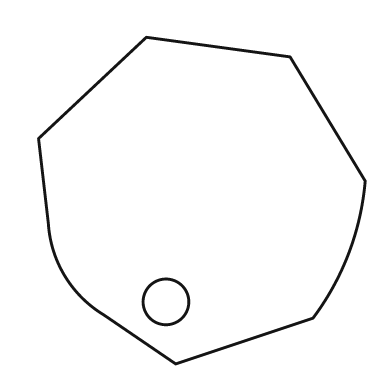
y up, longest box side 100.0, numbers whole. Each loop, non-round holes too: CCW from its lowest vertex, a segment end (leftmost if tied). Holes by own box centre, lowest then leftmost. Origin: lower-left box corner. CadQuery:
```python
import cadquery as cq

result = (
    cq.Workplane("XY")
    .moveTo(42.0, 0.0)
    .lineTo(84.0, 14.0)
    .threePointArc((95.0, 34.0), (100.0, 56.0))
    .lineTo(77.0, 94.0)
    .lineTo(33.0, 100.0)
    .lineTo(0.0, 69.0)
    .lineTo(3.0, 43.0)
    .threePointArc((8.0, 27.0), (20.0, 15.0))
    .close()
    .moveTo(39.0, 19.0)
    .circle(7.0)
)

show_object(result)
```